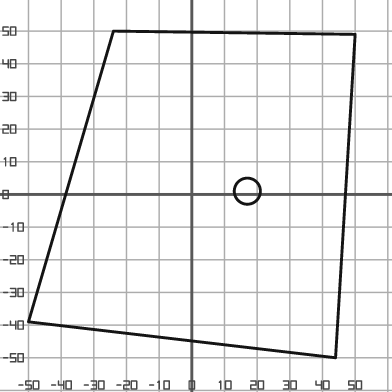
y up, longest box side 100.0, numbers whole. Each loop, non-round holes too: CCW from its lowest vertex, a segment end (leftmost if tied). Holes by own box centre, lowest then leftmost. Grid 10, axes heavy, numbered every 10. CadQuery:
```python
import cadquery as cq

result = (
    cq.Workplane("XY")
    .moveTo(44.0, -50.0)
    .lineTo(50.0, 49.0)
    .lineTo(-24.0, 50.0)
    .lineTo(-50.0, -39.0)
    .close()
    .moveTo(17.0, 1.0)
    .circle(4.0)
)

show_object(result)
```